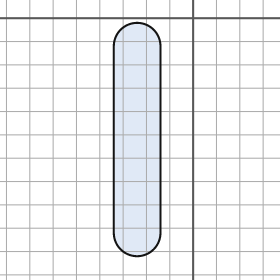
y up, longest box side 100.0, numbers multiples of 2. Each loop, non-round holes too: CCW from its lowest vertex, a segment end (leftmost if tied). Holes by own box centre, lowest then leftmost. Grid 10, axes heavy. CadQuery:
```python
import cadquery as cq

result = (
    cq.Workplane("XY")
    .moveTo(-34.0, -92.0)
    .threePointArc((-24.0, -102.0), (-14.0, -92.0))
    .lineTo(-14.0, -12.0)
    .threePointArc((-24.0, -2.0), (-34.0, -12.0))
    .close()
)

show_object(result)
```